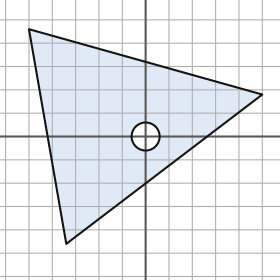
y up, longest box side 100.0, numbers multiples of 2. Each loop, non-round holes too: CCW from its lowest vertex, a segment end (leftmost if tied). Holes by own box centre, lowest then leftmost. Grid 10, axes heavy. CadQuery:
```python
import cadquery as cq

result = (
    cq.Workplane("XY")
    .moveTo(-34.0, -46.0)
    .lineTo(50.0, 18.0)
    .lineTo(-50.0, 46.0)
    .close()
    .moveTo(0.0, 0.0)
    .circle(6.0)
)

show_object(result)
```